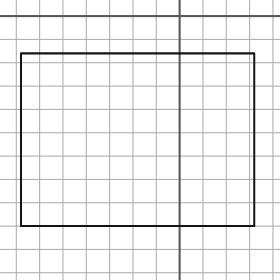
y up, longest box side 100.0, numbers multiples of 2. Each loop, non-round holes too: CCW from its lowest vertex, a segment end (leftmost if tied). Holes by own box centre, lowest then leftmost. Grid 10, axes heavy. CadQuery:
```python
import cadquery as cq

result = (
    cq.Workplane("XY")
    .moveTo(-68.0, -90.0)
    .lineTo(32.0, -90.0)
    .lineTo(32.0, -16.0)
    .lineTo(-68.0, -16.0)
    .close()
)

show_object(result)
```